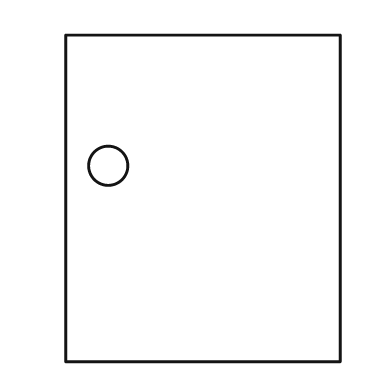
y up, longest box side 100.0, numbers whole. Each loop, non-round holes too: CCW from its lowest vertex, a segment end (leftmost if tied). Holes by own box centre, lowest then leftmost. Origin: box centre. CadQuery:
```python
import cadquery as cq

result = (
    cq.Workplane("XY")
    .moveTo(-42.0, -50.0)
    .lineTo(42.0, -50.0)
    .lineTo(42.0, 50.0)
    .lineTo(-42.0, 50.0)
    .close()
    .moveTo(-29.0, 10.0)
    .circle(6.0)
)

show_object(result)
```